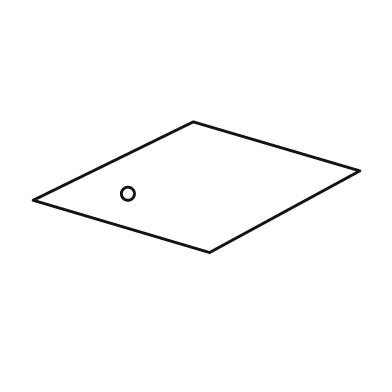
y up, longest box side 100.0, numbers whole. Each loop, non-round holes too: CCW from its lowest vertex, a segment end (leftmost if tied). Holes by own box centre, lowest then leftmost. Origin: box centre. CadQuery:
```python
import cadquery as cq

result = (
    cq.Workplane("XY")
    .moveTo(4.0, -20.0)
    .lineTo(50.0, 5.0)
    .lineTo(-1.0, 20.0)
    .lineTo(-50.0, -4.0)
    .close()
    .moveTo(-21.0, -2.0)
    .circle(2.0)
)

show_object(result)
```